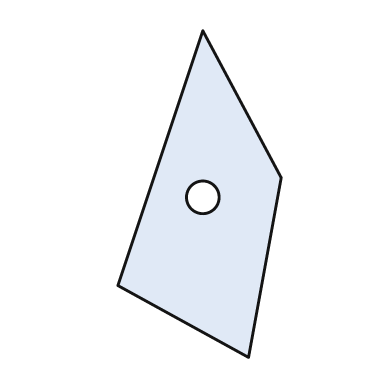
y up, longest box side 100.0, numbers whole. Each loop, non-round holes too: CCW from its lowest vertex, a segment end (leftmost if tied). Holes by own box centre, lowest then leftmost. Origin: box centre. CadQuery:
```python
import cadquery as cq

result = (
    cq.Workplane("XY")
    .moveTo(15.0, -50.0)
    .lineTo(25.0, 5.0)
    .lineTo(1.0, 50.0)
    .lineTo(-25.0, -28.0)
    .close()
    .moveTo(1.0, -1.0)
    .circle(5.0)
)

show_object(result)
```